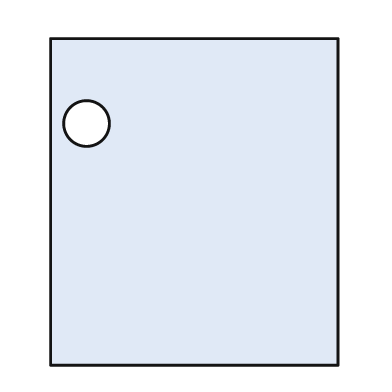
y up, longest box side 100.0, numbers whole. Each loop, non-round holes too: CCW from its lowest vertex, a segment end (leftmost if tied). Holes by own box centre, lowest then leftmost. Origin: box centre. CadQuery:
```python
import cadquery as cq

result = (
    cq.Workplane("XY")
    .moveTo(-44.0, -50.0)
    .lineTo(44.0, -50.0)
    .lineTo(44.0, 50.0)
    .lineTo(-44.0, 50.0)
    .close()
    .moveTo(-33.0, 24.0)
    .circle(7.0)
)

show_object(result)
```